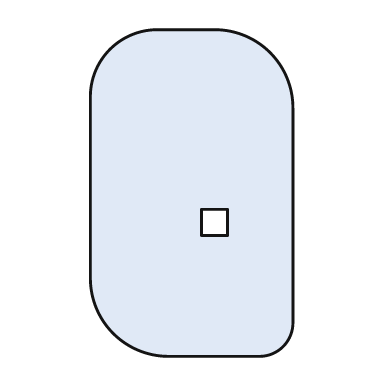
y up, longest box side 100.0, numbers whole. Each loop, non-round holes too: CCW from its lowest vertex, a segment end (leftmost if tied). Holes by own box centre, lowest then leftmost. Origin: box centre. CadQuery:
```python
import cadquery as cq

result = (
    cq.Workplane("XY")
    .moveTo(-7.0, -50.0)
    .lineTo(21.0, -50.0)
    .threePointArc((28.0, -47.0), (31.0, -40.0))
    .lineTo(31.0, 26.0)
    .threePointArc((24.0, 43.0), (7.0, 50.0))
    .lineTo(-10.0, 50.0)
    .threePointArc((-25.0, 44.0), (-31.0, 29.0))
    .lineTo(-31.0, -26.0)
    .threePointArc((-24.0, -43.0), (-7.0, -50.0))
    .close()
    .moveTo(3.0, -13.0)
    .lineTo(11.0, -13.0)
    .lineTo(11.0, -5.0)
    .lineTo(3.0, -5.0)
    .close()
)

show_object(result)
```